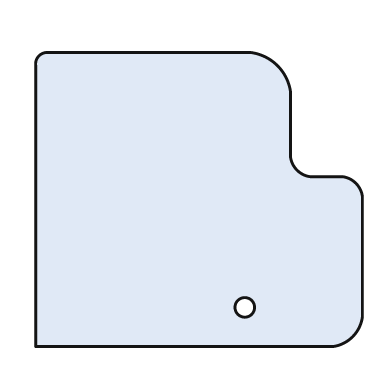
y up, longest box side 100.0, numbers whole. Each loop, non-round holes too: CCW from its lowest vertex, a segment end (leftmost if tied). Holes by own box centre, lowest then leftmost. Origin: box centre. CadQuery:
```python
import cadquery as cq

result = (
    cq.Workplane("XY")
    .moveTo(-50.0, -45.0)
    .lineTo(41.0, -45.0)
    .threePointArc((47.0, -42.0), (50.0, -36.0))
    .lineTo(50.0, 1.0)
    .threePointArc((48.0, 5.0), (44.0, 7.0))
    .lineTo(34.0, 7.0)
    .threePointArc((30.0, 9.0), (28.0, 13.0))
    .lineTo(28.0, 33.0)
    .threePointArc((24.0, 41.0), (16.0, 45.0))
    .lineTo(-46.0, 45.0)
    .threePointArc((-49.0, 44.0), (-50.0, 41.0))
    .close()
    .moveTo(14.0, -33.0)
    .circle(3.0)
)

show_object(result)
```